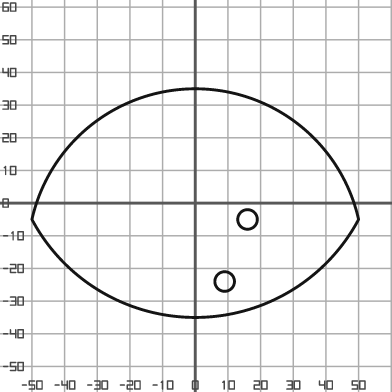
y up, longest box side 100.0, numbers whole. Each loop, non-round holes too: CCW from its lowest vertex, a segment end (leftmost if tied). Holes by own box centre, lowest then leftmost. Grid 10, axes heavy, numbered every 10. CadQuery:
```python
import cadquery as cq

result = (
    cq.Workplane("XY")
    .moveTo(-50.0, -5.0)
    .threePointArc((0.0, -35.0), (50.0, -5.0))
    .threePointArc((0.0, 35.0), (-50.0, -5.0))
    .close()
    .moveTo(9.0, -24.0)
    .circle(3.0)
    .moveTo(16.0, -5.0)
    .circle(3.0)
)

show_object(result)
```